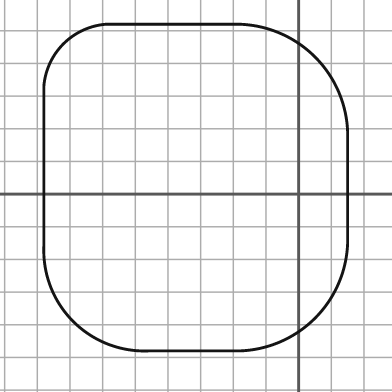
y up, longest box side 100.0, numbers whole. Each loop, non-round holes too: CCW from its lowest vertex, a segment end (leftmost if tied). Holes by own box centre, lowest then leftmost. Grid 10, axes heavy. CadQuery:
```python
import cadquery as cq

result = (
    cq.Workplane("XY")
    .moveTo(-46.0, -48.0)
    .lineTo(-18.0, -48.0)
    .threePointArc((5.0, -38.0), (15.0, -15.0))
    .lineTo(15.0, 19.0)
    .threePointArc((5.0, 42.0), (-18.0, 52.0))
    .lineTo(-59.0, 52.0)
    .threePointArc((-72.0, 46.0), (-78.0, 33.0))
    .lineTo(-78.0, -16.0)
    .threePointArc((-69.0, -39.0), (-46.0, -48.0))
    .close()
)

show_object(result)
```